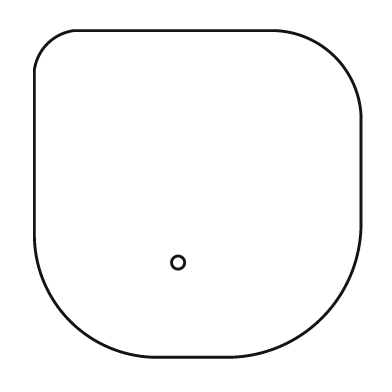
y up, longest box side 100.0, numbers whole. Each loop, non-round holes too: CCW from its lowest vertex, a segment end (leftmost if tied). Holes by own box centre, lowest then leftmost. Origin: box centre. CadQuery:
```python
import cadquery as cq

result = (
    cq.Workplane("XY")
    .moveTo(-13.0, -50.0)
    .lineTo(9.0, -50.0)
    .threePointArc((38.0, -38.0), (50.0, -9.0))
    .lineTo(50.0, 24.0)
    .threePointArc((42.0, 42.0), (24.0, 50.0))
    .lineTo(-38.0, 50.0)
    .threePointArc((-46.0, 46.0), (-50.0, 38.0))
    .lineTo(-50.0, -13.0)
    .threePointArc((-39.0, -39.0), (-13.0, -50.0))
    .close()
    .moveTo(-6.0, -21.0)
    .circle(2.0)
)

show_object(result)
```